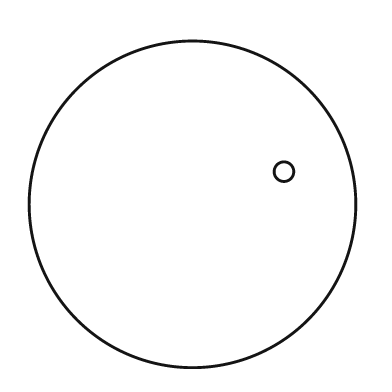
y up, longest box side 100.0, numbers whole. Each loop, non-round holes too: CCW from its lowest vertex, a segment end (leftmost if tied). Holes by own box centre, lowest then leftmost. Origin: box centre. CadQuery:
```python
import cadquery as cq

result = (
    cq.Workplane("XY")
    .moveTo(0.0, 0.0)
    .circle(50.0)
    .moveTo(28.0, 10.0)
    .circle(3.0)
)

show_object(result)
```